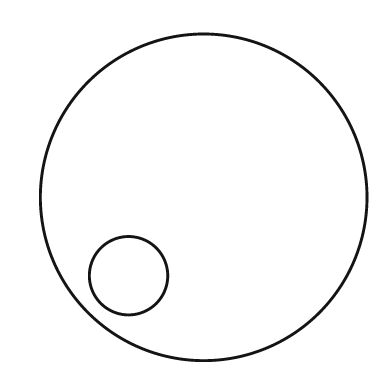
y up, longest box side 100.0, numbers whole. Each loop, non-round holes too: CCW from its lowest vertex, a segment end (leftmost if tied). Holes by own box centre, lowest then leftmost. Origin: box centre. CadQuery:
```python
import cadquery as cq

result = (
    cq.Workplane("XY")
    .moveTo(0.0, 0.0)
    .circle(50.0)
    .moveTo(-23.0, -24.0)
    .circle(12.0)
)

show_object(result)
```